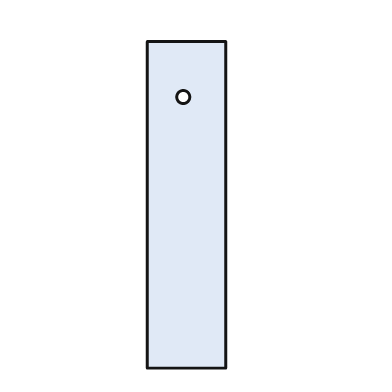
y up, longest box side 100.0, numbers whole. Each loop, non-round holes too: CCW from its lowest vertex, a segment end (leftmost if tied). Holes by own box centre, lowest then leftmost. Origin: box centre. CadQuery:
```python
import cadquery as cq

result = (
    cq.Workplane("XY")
    .moveTo(-12.0, -50.0)
    .lineTo(12.0, -50.0)
    .lineTo(12.0, 50.0)
    .lineTo(-12.0, 50.0)
    .close()
    .moveTo(-1.0, 33.0)
    .circle(2.0)
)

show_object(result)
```